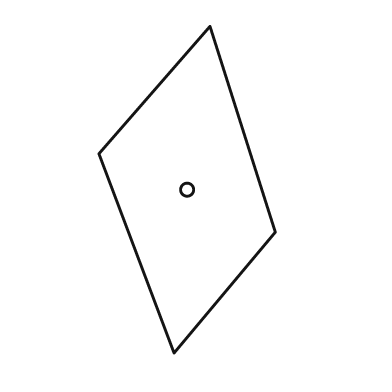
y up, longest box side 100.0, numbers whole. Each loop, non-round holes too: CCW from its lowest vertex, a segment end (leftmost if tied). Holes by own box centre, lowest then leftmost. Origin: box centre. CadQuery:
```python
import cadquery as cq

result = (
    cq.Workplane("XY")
    .moveTo(-4.0, -50.0)
    .lineTo(27.0, -13.0)
    .lineTo(7.0, 50.0)
    .lineTo(-27.0, 11.0)
    .close()
    .moveTo(0.0, 0.0)
    .circle(2.0)
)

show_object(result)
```